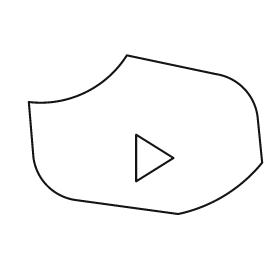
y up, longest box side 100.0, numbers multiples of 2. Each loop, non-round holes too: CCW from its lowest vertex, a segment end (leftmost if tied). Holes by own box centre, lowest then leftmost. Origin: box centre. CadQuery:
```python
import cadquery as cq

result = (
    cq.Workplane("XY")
    .moveTo(14.0, -34.0)
    .threePointArc((34.0, -26.0), (50.0, -12.0))
    .lineTo(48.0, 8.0)
    .threePointArc((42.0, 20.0), (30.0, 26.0))
    .lineTo(-8.0, 34.0)
    .threePointArc((-26.0, 18.0), (-50.0, 14.0))
    .lineTo(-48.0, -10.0)
    .threePointArc((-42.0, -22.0), (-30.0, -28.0))
    .close()
    .moveTo(-4.0, -20.0)
    .lineTo(12.0, -10.0)
    .lineTo(-4.0, 0.0)
    .close()
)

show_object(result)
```